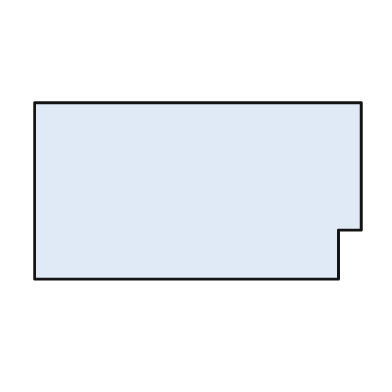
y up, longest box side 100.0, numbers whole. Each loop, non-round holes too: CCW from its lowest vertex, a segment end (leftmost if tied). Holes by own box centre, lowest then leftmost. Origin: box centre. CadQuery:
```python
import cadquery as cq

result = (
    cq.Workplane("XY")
    .moveTo(-50.0, -27.0)
    .lineTo(43.0, -27.0)
    .lineTo(43.0, -12.0)
    .lineTo(50.0, -12.0)
    .lineTo(50.0, 27.0)
    .lineTo(-50.0, 27.0)
    .close()
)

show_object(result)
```